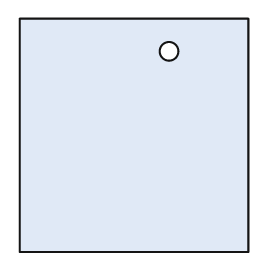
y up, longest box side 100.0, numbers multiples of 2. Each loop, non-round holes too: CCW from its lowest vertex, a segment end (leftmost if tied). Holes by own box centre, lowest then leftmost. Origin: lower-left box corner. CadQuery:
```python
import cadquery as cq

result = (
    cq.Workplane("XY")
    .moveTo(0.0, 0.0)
    .lineTo(98.0, 0.0)
    .lineTo(98.0, 100.0)
    .lineTo(0.0, 100.0)
    .close()
    .moveTo(64.0, 86.0)
    .circle(4.0)
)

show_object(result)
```